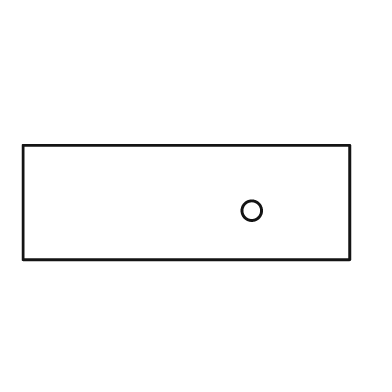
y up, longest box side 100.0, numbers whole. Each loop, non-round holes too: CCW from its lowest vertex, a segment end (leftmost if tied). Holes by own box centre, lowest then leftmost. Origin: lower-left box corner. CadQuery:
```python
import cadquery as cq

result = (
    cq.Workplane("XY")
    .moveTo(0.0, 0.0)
    .lineTo(100.0, 0.0)
    .lineTo(100.0, 35.0)
    .lineTo(0.0, 35.0)
    .close()
    .moveTo(70.0, 15.0)
    .circle(3.0)
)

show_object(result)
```